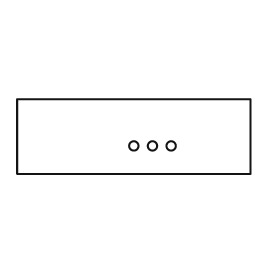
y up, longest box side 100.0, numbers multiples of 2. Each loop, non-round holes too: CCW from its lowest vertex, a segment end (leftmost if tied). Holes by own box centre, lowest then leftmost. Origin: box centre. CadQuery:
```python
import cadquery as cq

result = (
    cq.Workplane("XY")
    .moveTo(-50.0, -16.0)
    .lineTo(50.0, -16.0)
    .lineTo(50.0, 16.0)
    .lineTo(-50.0, 16.0)
    .close()
    .moveTo(0.0, -4.0)
    .circle(2.0)
    .moveTo(8.0, -4.0)
    .circle(2.0)
    .moveTo(16.0, -4.0)
    .circle(2.0)
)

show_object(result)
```